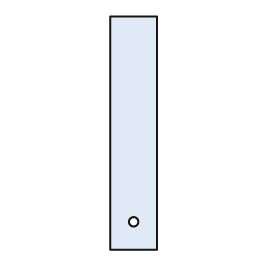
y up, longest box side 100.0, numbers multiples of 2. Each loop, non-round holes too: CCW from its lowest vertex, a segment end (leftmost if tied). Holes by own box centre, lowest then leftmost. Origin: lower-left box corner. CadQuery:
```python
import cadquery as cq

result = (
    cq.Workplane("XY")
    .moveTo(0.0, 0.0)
    .lineTo(20.0, 0.0)
    .lineTo(20.0, 100.0)
    .lineTo(0.0, 100.0)
    .close()
    .moveTo(10.0, 12.0)
    .circle(2.0)
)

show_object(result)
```